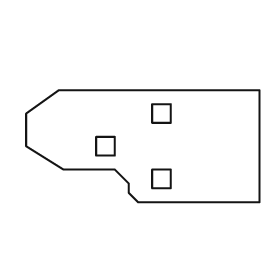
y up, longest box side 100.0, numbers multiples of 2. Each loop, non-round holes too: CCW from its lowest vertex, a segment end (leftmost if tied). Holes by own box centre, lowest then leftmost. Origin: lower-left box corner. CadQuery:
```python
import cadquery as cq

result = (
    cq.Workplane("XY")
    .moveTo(48.0, 0.0)
    .lineTo(100.0, 0.0)
    .lineTo(100.0, 48.0)
    .lineTo(14.0, 48.0)
    .lineTo(0.0, 38.0)
    .lineTo(0.0, 24.0)
    .lineTo(16.0, 14.0)
    .lineTo(38.0, 14.0)
    .lineTo(44.0, 8.0)
    .lineTo(44.0, 4.0)
    .close()
    .moveTo(54.0, 6.0)
    .lineTo(62.0, 6.0)
    .lineTo(62.0, 14.0)
    .lineTo(54.0, 14.0)
    .close()
    .moveTo(30.0, 20.0)
    .lineTo(38.0, 20.0)
    .lineTo(38.0, 28.0)
    .lineTo(30.0, 28.0)
    .close()
    .moveTo(54.0, 34.0)
    .lineTo(62.0, 34.0)
    .lineTo(62.0, 42.0)
    .lineTo(54.0, 42.0)
    .close()
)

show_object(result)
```